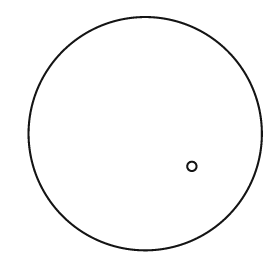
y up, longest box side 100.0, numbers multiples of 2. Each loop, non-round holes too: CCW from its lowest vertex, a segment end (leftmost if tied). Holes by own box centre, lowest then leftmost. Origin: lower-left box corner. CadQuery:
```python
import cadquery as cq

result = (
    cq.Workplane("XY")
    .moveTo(50.0, 50.0)
    .circle(50.0)
    .moveTo(70.0, 36.0)
    .circle(2.0)
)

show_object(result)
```